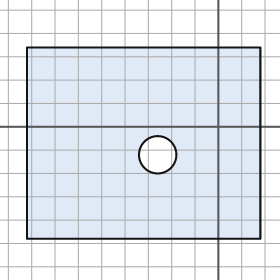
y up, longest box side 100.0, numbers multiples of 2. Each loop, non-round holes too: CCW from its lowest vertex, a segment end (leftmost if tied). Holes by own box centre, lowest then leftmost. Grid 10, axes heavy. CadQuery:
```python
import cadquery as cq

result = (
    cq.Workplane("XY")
    .moveTo(-82.0, -48.0)
    .lineTo(18.0, -48.0)
    .lineTo(18.0, 34.0)
    .lineTo(-82.0, 34.0)
    .close()
    .moveTo(-26.0, -12.0)
    .circle(8.0)
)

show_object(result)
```